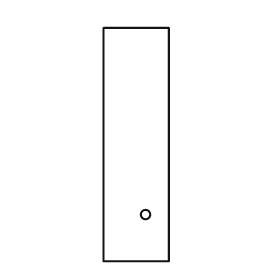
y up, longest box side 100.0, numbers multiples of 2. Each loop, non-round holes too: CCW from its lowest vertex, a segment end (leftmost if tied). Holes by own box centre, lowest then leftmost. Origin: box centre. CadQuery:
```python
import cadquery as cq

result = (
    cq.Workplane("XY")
    .moveTo(-14.0, -50.0)
    .lineTo(14.0, -50.0)
    .lineTo(14.0, 50.0)
    .lineTo(-14.0, 50.0)
    .close()
    .moveTo(4.0, -30.0)
    .circle(2.0)
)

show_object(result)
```